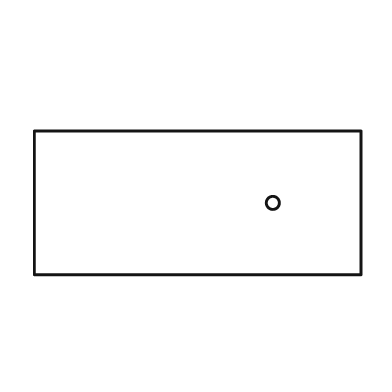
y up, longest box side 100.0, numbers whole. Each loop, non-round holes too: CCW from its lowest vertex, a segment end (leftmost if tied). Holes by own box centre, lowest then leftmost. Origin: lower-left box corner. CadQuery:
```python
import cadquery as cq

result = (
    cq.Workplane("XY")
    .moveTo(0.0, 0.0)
    .lineTo(100.0, 0.0)
    .lineTo(100.0, 44.0)
    .lineTo(0.0, 44.0)
    .close()
    .moveTo(73.0, 22.0)
    .circle(2.0)
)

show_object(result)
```